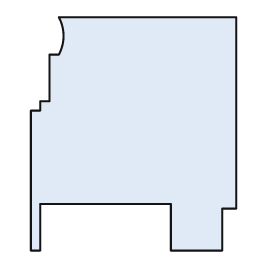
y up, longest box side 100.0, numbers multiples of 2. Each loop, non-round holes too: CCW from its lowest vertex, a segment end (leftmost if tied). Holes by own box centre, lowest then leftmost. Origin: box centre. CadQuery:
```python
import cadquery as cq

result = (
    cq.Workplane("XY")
    .moveTo(-44.0, -50.0)
    .lineTo(-40.0, -50.0)
    .lineTo(-40.0, -30.0)
    .lineTo(16.0, -30.0)
    .lineTo(16.0, -50.0)
    .lineTo(38.0, -50.0)
    .lineTo(38.0, -32.0)
    .lineTo(44.0, -32.0)
    .lineTo(44.0, 50.0)
    .lineTo(-32.0, 50.0)
    .threePointArc((-30.0, 42.0), (-32.0, 34.0))
    .lineTo(-36.0, 34.0)
    .lineTo(-36.0, 14.0)
    .lineTo(-40.0, 14.0)
    .lineTo(-40.0, 10.0)
    .lineTo(-44.0, 10.0)
    .close()
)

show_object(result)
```